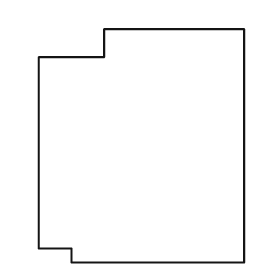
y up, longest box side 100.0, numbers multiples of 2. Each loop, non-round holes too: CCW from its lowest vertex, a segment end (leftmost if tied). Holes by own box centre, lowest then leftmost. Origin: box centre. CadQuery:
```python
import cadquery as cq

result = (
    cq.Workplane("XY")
    .moveTo(-30.0, -50.0)
    .lineTo(44.0, -50.0)
    .lineTo(44.0, 50.0)
    .lineTo(-16.0, 50.0)
    .lineTo(-16.0, 38.0)
    .lineTo(-44.0, 38.0)
    .lineTo(-44.0, -44.0)
    .lineTo(-30.0, -44.0)
    .close()
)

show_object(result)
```